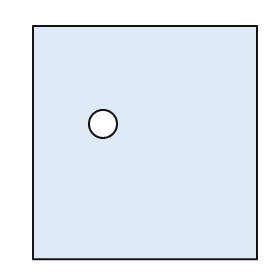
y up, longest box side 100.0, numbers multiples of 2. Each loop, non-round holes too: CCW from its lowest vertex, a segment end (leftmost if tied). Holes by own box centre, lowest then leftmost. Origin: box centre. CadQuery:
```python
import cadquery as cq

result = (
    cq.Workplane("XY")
    .moveTo(-48.0, -50.0)
    .lineTo(48.0, -50.0)
    .lineTo(48.0, 50.0)
    .lineTo(-48.0, 50.0)
    .close()
    .moveTo(-18.0, 8.0)
    .circle(6.0)
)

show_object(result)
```